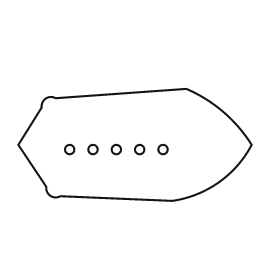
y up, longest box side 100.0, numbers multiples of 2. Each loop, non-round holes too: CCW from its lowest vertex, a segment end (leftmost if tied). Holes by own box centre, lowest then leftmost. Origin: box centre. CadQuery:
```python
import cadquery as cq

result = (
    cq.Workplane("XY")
    .moveTo(16.0, -24.0)
    .threePointArc((36.0, -16.0), (50.0, 0.0))
    .threePointArc((38.0, 14.0), (22.0, 24.0))
    .lineTo(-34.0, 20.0)
    .threePointArc((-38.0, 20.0), (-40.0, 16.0))
    .lineTo(-50.0, 0.0)
    .lineTo(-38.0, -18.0)
    .threePointArc((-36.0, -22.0), (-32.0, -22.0))
    .close()
    .moveTo(-28.0, -2.0)
    .circle(2.0)
    .moveTo(-18.0, -2.0)
    .circle(2.0)
    .moveTo(-8.0, -2.0)
    .circle(2.0)
    .moveTo(2.0, -2.0)
    .circle(2.0)
    .moveTo(12.0, -2.0)
    .circle(2.0)
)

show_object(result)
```